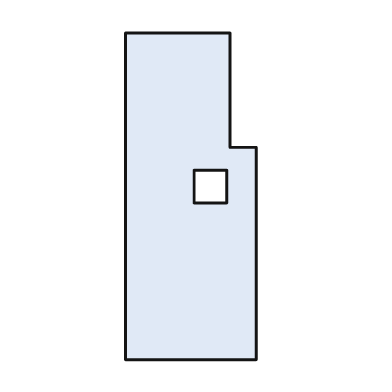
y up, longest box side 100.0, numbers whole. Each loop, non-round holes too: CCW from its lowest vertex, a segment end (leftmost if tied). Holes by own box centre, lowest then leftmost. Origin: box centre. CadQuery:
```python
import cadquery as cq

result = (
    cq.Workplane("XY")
    .moveTo(-20.0, -50.0)
    .lineTo(20.0, -50.0)
    .lineTo(20.0, 15.0)
    .lineTo(12.0, 15.0)
    .lineTo(12.0, 50.0)
    .lineTo(-20.0, 50.0)
    .close()
    .moveTo(1.0, -2.0)
    .lineTo(11.0, -2.0)
    .lineTo(11.0, 8.0)
    .lineTo(1.0, 8.0)
    .close()
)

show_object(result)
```